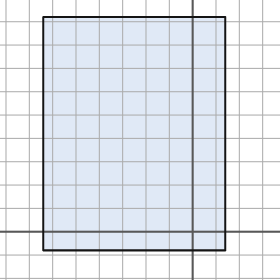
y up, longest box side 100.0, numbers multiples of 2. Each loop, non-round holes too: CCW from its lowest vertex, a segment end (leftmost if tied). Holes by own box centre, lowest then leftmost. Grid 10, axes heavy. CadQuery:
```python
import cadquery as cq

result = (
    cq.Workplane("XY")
    .moveTo(-64.0, -8.0)
    .lineTo(14.0, -8.0)
    .lineTo(14.0, 92.0)
    .lineTo(-64.0, 92.0)
    .close()
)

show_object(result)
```